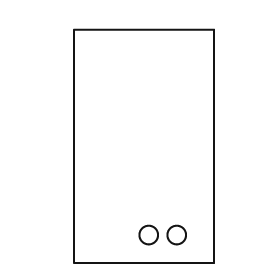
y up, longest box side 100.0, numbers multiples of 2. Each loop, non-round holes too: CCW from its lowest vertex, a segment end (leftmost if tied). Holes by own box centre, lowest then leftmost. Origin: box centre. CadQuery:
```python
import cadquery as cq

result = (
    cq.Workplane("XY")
    .moveTo(-30.0, -50.0)
    .lineTo(30.0, -50.0)
    .lineTo(30.0, 50.0)
    .lineTo(-30.0, 50.0)
    .close()
    .moveTo(2.0, -38.0)
    .circle(4.0)
    .moveTo(14.0, -38.0)
    .circle(4.0)
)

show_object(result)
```